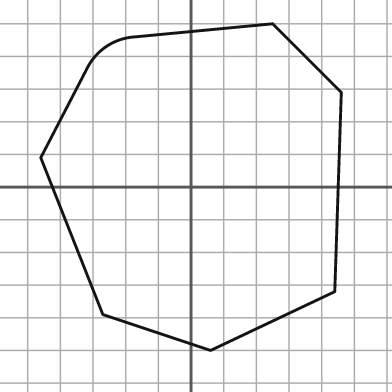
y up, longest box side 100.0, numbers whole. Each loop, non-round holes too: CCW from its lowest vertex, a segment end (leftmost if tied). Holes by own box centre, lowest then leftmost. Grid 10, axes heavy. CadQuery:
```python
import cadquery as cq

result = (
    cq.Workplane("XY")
    .moveTo(6.0, -50.0)
    .lineTo(44.0, -32.0)
    .lineTo(46.0, 29.0)
    .lineTo(25.0, 50.0)
    .lineTo(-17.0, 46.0)
    .threePointArc((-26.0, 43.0), (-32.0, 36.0))
    .lineTo(-46.0, 9.0)
    .lineTo(-27.0, -39.0)
    .close()
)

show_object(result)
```